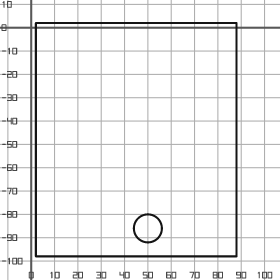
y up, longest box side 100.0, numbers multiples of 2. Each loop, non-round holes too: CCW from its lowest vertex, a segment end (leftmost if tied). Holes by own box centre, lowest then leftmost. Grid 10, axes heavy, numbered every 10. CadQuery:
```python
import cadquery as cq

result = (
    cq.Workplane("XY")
    .moveTo(2.0, -98.0)
    .lineTo(88.0, -98.0)
    .lineTo(88.0, 2.0)
    .lineTo(2.0, 2.0)
    .close()
    .moveTo(50.0, -86.0)
    .circle(6.0)
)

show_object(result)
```